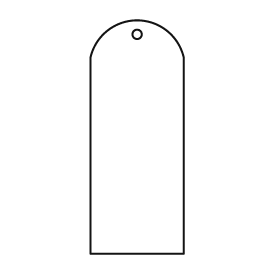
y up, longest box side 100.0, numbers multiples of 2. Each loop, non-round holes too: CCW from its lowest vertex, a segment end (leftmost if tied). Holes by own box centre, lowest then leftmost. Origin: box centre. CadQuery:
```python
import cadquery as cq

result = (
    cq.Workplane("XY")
    .moveTo(-20.0, -50.0)
    .lineTo(20.0, -50.0)
    .lineTo(20.0, 34.0)
    .threePointArc((0.0, 50.0), (-20.0, 34.0))
    .close()
    .moveTo(0.0, 44.0)
    .circle(2.0)
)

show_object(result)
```